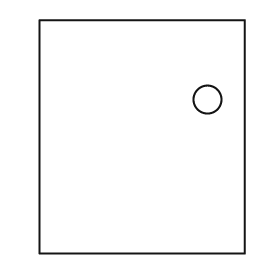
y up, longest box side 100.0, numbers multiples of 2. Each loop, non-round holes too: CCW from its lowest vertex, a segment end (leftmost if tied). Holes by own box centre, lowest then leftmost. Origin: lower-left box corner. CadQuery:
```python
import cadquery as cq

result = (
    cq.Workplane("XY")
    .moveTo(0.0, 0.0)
    .lineTo(88.0, 0.0)
    .lineTo(88.0, 100.0)
    .lineTo(0.0, 100.0)
    .close()
    .moveTo(72.0, 66.0)
    .circle(6.0)
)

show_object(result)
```